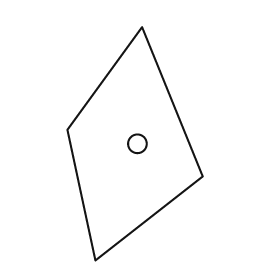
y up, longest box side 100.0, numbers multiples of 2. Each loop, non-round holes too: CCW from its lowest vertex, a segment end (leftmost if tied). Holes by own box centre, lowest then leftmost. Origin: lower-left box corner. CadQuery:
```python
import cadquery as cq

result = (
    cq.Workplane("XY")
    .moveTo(12.0, 0.0)
    .lineTo(58.0, 36.0)
    .lineTo(32.0, 100.0)
    .lineTo(0.0, 56.0)
    .close()
    .moveTo(30.0, 50.0)
    .circle(4.0)
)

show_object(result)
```